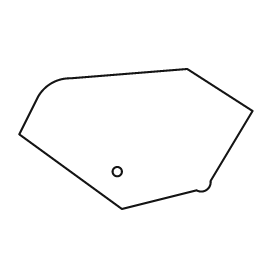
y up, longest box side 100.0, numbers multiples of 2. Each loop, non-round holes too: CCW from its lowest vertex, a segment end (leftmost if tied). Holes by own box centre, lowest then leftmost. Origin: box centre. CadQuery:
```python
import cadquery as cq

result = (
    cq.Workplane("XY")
    .moveTo(-6.0, -30.0)
    .lineTo(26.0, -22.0)
    .threePointArc((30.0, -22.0), (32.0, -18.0))
    .lineTo(50.0, 12.0)
    .lineTo(22.0, 30.0)
    .lineTo(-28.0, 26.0)
    .threePointArc((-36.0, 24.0), (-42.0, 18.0))
    .lineTo(-50.0, 2.0)
    .close()
    .moveTo(-8.0, -14.0)
    .circle(2.0)
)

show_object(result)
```